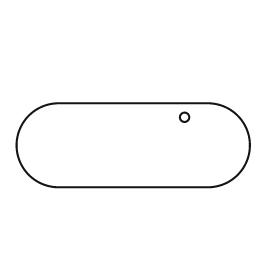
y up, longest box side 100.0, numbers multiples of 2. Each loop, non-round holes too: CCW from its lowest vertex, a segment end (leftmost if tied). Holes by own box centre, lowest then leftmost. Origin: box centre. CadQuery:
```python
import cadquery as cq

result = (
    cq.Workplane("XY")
    .moveTo(-32.0, -18.0)
    .lineTo(32.0, -18.0)
    .threePointArc((50.0, 0.0), (32.0, 18.0))
    .lineTo(-32.0, 18.0)
    .threePointArc((-50.0, 0.0), (-32.0, -18.0))
    .close()
    .moveTo(22.0, 12.0)
    .circle(2.0)
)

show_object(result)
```